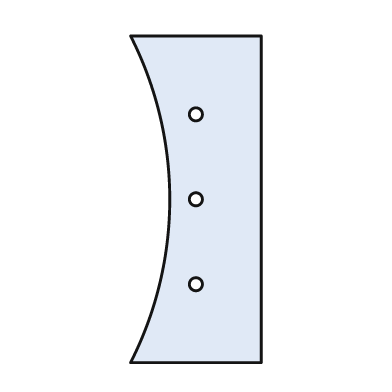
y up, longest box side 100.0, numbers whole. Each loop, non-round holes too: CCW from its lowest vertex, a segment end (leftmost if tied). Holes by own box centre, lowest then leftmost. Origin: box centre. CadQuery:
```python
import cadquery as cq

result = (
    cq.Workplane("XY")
    .moveTo(-20.0, -50.0)
    .lineTo(20.0, -50.0)
    .lineTo(20.0, 50.0)
    .lineTo(-20.0, 50.0)
    .threePointArc((-8.0, 0.0), (-20.0, -50.0))
    .close()
    .moveTo(0.0, -26.0)
    .circle(2.0)
    .moveTo(0.0, 0.0)
    .circle(2.0)
    .moveTo(0.0, 26.0)
    .circle(2.0)
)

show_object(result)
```